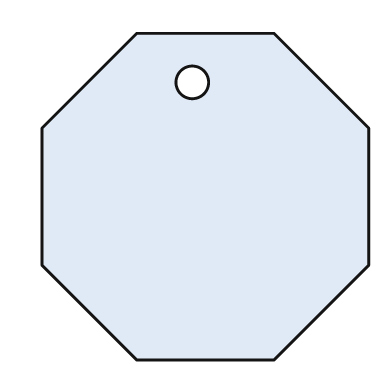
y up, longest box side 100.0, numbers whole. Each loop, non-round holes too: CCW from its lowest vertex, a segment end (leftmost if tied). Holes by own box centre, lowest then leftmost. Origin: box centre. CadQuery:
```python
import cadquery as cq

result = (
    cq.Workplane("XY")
    .moveTo(-21.0, -50.0)
    .lineTo(21.0, -50.0)
    .lineTo(50.0, -21.0)
    .lineTo(50.0, 21.0)
    .lineTo(21.0, 50.0)
    .lineTo(-21.0, 50.0)
    .lineTo(-50.0, 21.0)
    .lineTo(-50.0, -21.0)
    .close()
    .moveTo(-4.0, 35.0)
    .circle(5.0)
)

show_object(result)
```